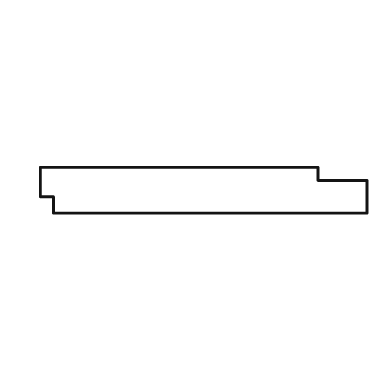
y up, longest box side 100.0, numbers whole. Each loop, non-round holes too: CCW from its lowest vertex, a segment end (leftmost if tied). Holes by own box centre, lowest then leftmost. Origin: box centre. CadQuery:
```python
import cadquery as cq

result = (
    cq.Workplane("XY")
    .moveTo(-46.0, -7.0)
    .lineTo(50.0, -7.0)
    .lineTo(50.0, 3.0)
    .lineTo(35.0, 3.0)
    .lineTo(35.0, 7.0)
    .lineTo(-50.0, 7.0)
    .lineTo(-50.0, -2.0)
    .lineTo(-46.0, -2.0)
    .close()
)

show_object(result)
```